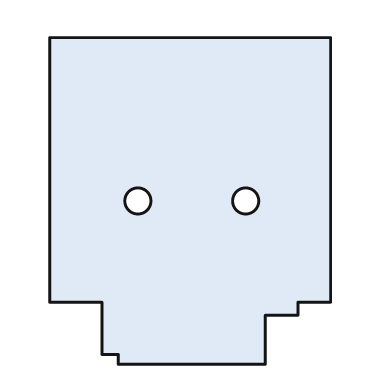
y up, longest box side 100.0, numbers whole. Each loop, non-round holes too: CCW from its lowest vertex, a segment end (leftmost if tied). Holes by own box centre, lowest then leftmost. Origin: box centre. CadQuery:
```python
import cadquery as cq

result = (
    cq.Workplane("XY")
    .moveTo(-22.0, -50.0)
    .lineTo(23.0, -50.0)
    .lineTo(23.0, -35.0)
    .lineTo(33.0, -35.0)
    .lineTo(33.0, -31.0)
    .lineTo(43.0, -31.0)
    .lineTo(43.0, 50.0)
    .lineTo(-43.0, 50.0)
    .lineTo(-43.0, -31.0)
    .lineTo(-27.0, -31.0)
    .lineTo(-27.0, -47.0)
    .lineTo(-22.0, -47.0)
    .close()
    .moveTo(-16.0, 0.0)
    .circle(4.0)
    .moveTo(17.0, 0.0)
    .circle(4.0)
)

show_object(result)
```